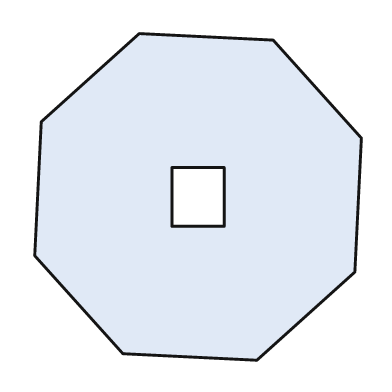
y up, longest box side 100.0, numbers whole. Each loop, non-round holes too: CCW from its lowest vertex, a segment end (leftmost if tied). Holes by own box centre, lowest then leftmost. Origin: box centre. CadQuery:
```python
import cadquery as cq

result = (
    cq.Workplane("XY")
    .moveTo(18.0, -50.0)
    .lineTo(48.0, -23.0)
    .lineTo(50.0, 18.0)
    .lineTo(23.0, 48.0)
    .lineTo(-18.0, 50.0)
    .lineTo(-48.0, 23.0)
    .lineTo(-50.0, -18.0)
    .lineTo(-23.0, -48.0)
    .close()
    .moveTo(-8.0, -9.0)
    .lineTo(8.0, -9.0)
    .lineTo(8.0, 9.0)
    .lineTo(-8.0, 9.0)
    .close()
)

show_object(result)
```